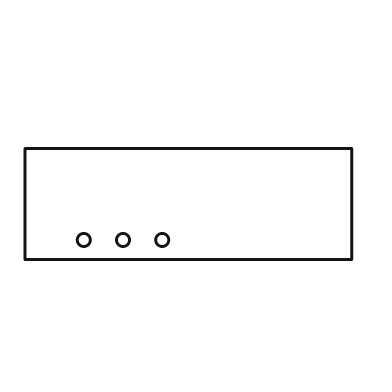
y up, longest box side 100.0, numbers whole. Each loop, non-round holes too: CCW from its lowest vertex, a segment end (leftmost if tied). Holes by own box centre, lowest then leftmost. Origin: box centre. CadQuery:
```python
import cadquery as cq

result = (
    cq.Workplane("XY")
    .moveTo(-50.0, -17.0)
    .lineTo(50.0, -17.0)
    .lineTo(50.0, 17.0)
    .lineTo(-50.0, 17.0)
    .close()
    .moveTo(-32.0, -11.0)
    .circle(2.0)
    .moveTo(-20.0, -11.0)
    .circle(2.0)
    .moveTo(-8.0, -11.0)
    .circle(2.0)
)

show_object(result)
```